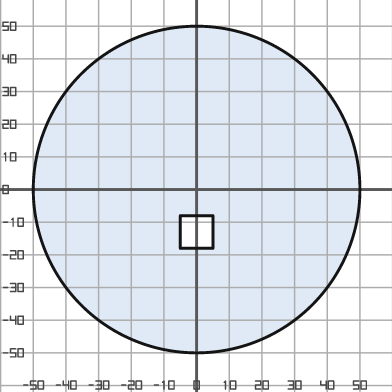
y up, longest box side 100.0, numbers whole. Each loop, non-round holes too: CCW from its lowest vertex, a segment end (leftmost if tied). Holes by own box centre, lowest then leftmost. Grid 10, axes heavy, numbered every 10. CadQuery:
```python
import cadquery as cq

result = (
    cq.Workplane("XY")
    .moveTo(0.0, 0.0)
    .circle(50.0)
    .moveTo(-5.0, -18.0)
    .lineTo(5.0, -18.0)
    .lineTo(5.0, -8.0)
    .lineTo(-5.0, -8.0)
    .close()
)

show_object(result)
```